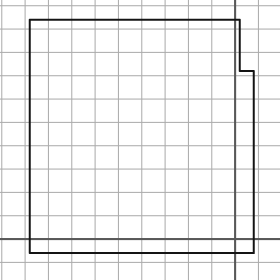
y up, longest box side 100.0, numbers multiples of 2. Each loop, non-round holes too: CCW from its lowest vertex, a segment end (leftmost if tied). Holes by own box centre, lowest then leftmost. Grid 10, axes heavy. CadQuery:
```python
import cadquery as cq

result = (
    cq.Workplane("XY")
    .moveTo(-88.0, -6.0)
    .lineTo(8.0, -6.0)
    .lineTo(8.0, 72.0)
    .lineTo(2.0, 72.0)
    .lineTo(2.0, 94.0)
    .lineTo(-88.0, 94.0)
    .close()
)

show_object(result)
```